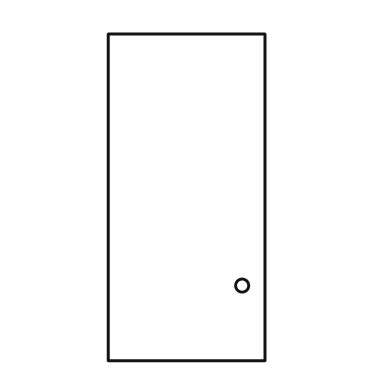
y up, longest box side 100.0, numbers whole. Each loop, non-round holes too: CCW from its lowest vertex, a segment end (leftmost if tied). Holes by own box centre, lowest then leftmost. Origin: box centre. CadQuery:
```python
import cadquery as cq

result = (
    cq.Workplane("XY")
    .moveTo(-24.0, -50.0)
    .lineTo(24.0, -50.0)
    .lineTo(24.0, 50.0)
    .lineTo(-24.0, 50.0)
    .close()
    .moveTo(17.0, -27.0)
    .circle(2.0)
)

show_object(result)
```